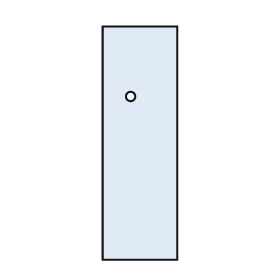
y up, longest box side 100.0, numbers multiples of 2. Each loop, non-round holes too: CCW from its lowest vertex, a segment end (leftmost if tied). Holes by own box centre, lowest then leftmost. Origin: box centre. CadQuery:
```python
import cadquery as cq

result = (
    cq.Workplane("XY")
    .moveTo(-16.0, -50.0)
    .lineTo(16.0, -50.0)
    .lineTo(16.0, 50.0)
    .lineTo(-16.0, 50.0)
    .close()
    .moveTo(-4.0, 20.0)
    .circle(2.0)
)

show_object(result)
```